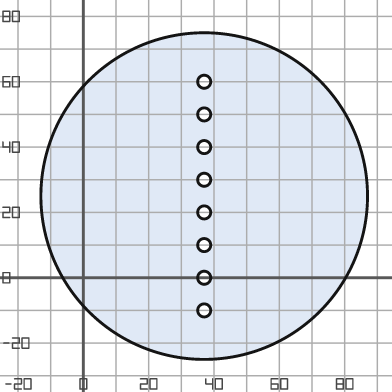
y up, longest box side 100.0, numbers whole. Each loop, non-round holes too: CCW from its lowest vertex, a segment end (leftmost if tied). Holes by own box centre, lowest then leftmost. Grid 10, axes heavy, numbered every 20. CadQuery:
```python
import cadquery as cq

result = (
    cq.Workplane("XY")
    .moveTo(37.0, 25.0)
    .circle(50.0)
    .moveTo(37.0, -10.0)
    .circle(2.0)
    .moveTo(37.0, 0.0)
    .circle(2.0)
    .moveTo(37.0, 10.0)
    .circle(2.0)
    .moveTo(37.0, 20.0)
    .circle(2.0)
    .moveTo(37.0, 30.0)
    .circle(2.0)
    .moveTo(37.0, 40.0)
    .circle(2.0)
    .moveTo(37.0, 50.0)
    .circle(2.0)
    .moveTo(37.0, 60.0)
    .circle(2.0)
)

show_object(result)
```